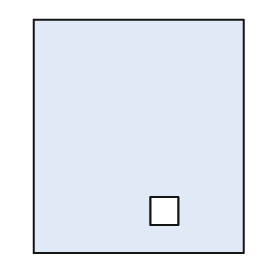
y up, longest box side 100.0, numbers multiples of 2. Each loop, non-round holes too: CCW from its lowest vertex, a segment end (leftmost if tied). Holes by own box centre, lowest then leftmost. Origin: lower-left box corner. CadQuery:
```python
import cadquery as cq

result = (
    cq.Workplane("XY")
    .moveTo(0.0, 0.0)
    .lineTo(90.0, 0.0)
    .lineTo(90.0, 100.0)
    .lineTo(0.0, 100.0)
    .close()
    .moveTo(50.0, 12.0)
    .lineTo(62.0, 12.0)
    .lineTo(62.0, 24.0)
    .lineTo(50.0, 24.0)
    .close()
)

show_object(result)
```